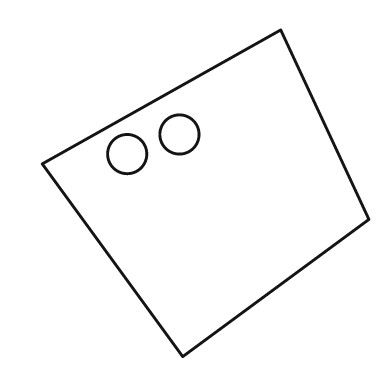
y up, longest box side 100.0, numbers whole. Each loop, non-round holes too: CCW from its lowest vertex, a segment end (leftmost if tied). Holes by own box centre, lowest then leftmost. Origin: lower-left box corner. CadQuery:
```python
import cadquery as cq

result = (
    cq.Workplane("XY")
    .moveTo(43.0, 0.0)
    .lineTo(100.0, 42.0)
    .lineTo(73.0, 100.0)
    .lineTo(0.0, 59.0)
    .close()
    .moveTo(26.0, 62.0)
    .circle(6.0)
    .moveTo(42.0, 68.0)
    .circle(6.0)
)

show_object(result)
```